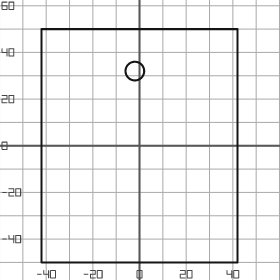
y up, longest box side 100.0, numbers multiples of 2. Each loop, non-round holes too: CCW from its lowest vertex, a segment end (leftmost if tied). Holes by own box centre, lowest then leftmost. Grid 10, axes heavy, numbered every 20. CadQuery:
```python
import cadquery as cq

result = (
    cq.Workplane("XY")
    .moveTo(-42.0, -50.0)
    .lineTo(42.0, -50.0)
    .lineTo(42.0, 50.0)
    .lineTo(-42.0, 50.0)
    .close()
    .moveTo(-2.0, 32.0)
    .circle(4.0)
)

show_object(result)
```